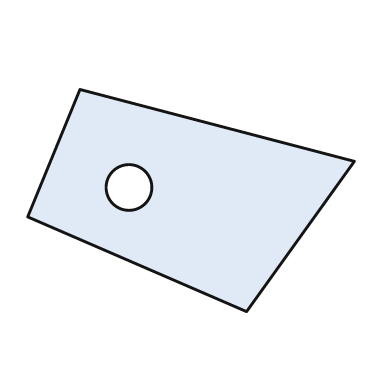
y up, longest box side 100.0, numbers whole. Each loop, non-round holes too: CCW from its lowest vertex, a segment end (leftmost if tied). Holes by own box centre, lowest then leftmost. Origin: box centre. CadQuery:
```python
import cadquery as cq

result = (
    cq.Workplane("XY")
    .moveTo(17.0, -34.0)
    .lineTo(50.0, 12.0)
    .lineTo(-34.0, 34.0)
    .lineTo(-50.0, -5.0)
    .close()
    .moveTo(-19.0, 4.0)
    .circle(7.0)
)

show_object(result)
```